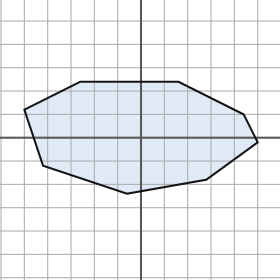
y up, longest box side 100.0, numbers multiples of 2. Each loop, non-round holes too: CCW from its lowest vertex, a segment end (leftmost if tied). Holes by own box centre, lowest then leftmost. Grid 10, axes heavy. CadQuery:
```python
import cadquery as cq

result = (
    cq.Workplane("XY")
    .moveTo(-6.0, -24.0)
    .lineTo(28.0, -18.0)
    .lineTo(50.0, -2.0)
    .lineTo(44.0, 10.0)
    .lineTo(16.0, 24.0)
    .lineTo(-26.0, 24.0)
    .lineTo(-50.0, 12.0)
    .lineTo(-42.0, -12.0)
    .close()
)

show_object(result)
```